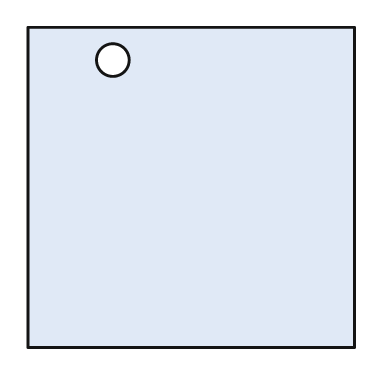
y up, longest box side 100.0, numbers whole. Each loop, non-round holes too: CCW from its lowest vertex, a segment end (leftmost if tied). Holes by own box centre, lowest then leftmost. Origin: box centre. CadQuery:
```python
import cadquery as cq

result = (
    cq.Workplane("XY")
    .moveTo(-50.0, -49.0)
    .lineTo(50.0, -49.0)
    .lineTo(50.0, 49.0)
    .lineTo(-50.0, 49.0)
    .close()
    .moveTo(-24.0, 39.0)
    .circle(5.0)
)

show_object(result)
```